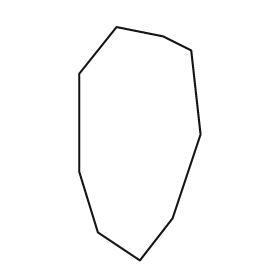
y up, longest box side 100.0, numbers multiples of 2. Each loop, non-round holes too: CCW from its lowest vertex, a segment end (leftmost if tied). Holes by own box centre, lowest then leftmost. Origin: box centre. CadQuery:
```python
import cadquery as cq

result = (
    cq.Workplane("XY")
    .moveTo(0.0, -50.0)
    .lineTo(14.0, -32.0)
    .lineTo(26.0, 4.0)
    .lineTo(22.0, 40.0)
    .lineTo(10.0, 46.0)
    .lineTo(-10.0, 50.0)
    .lineTo(-26.0, 30.0)
    .lineTo(-26.0, -12.0)
    .lineTo(-18.0, -38.0)
    .close()
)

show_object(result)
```